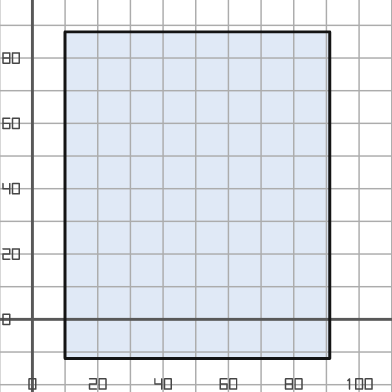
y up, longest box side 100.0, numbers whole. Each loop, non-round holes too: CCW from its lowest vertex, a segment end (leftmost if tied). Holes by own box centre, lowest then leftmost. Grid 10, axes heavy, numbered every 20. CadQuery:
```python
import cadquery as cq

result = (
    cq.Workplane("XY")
    .moveTo(10.0, -12.0)
    .lineTo(91.0, -12.0)
    .lineTo(91.0, 88.0)
    .lineTo(10.0, 88.0)
    .close()
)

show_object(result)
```